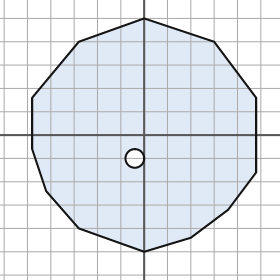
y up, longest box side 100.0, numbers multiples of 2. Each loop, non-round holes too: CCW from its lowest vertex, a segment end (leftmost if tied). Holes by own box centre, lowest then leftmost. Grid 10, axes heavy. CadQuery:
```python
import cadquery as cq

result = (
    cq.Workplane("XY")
    .moveTo(0.0, -50.0)
    .lineTo(20.0, -44.0)
    .lineTo(36.0, -32.0)
    .lineTo(48.0, -16.0)
    .lineTo(48.0, 16.0)
    .lineTo(30.0, 40.0)
    .lineTo(0.0, 50.0)
    .lineTo(-28.0, 40.0)
    .lineTo(-48.0, 16.0)
    .lineTo(-48.0, -6.0)
    .lineTo(-42.0, -24.0)
    .lineTo(-28.0, -40.0)
    .close()
    .moveTo(-4.0, -10.0)
    .circle(4.0)
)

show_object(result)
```